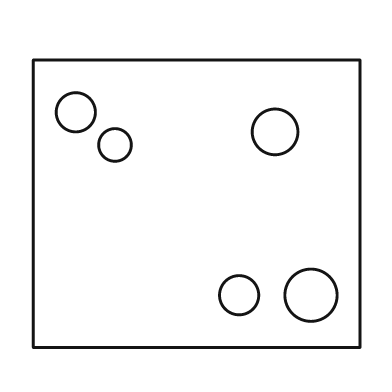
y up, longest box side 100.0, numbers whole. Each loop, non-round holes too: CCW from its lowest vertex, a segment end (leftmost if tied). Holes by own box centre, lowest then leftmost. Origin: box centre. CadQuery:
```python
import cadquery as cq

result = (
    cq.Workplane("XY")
    .moveTo(-50.0, -44.0)
    .lineTo(50.0, -44.0)
    .lineTo(50.0, 44.0)
    .lineTo(-50.0, 44.0)
    .close()
    .moveTo(13.0, -28.0)
    .circle(6.0)
    .moveTo(35.0, -28.0)
    .circle(8.0)
    .moveTo(-25.0, 18.0)
    .circle(5.0)
    .moveTo(24.0, 22.0)
    .circle(7.0)
    .moveTo(-37.0, 28.0)
    .circle(6.0)
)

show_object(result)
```